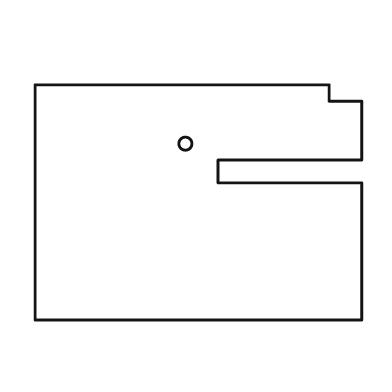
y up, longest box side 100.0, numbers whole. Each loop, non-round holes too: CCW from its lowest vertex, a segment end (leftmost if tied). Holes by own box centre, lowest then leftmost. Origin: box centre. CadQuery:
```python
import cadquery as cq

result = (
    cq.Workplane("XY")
    .moveTo(-50.0, -36.0)
    .lineTo(50.0, -36.0)
    .lineTo(50.0, 6.0)
    .lineTo(6.0, 6.0)
    .lineTo(6.0, 13.0)
    .lineTo(50.0, 13.0)
    .lineTo(50.0, 31.0)
    .lineTo(40.0, 31.0)
    .lineTo(40.0, 36.0)
    .lineTo(-50.0, 36.0)
    .close()
    .moveTo(-4.0, 18.0)
    .circle(2.0)
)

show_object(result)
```